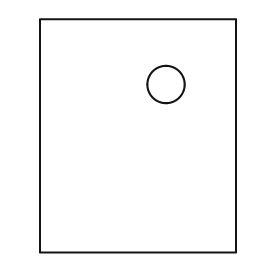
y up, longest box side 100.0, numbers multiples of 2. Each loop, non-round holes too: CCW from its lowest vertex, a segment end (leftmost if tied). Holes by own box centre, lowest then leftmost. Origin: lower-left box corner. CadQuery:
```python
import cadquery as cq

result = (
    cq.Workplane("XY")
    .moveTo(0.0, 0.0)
    .lineTo(84.0, 0.0)
    .lineTo(84.0, 100.0)
    .lineTo(0.0, 100.0)
    .close()
    .moveTo(54.0, 72.0)
    .circle(8.0)
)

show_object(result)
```